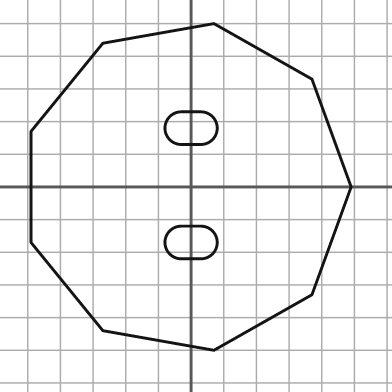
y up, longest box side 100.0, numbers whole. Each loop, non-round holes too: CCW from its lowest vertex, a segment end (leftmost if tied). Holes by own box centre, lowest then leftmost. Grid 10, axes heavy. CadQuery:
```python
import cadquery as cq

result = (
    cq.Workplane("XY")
    .moveTo(7.0, -50.0)
    .lineTo(37.0, -33.0)
    .lineTo(49.0, 0.0)
    .lineTo(37.0, 33.0)
    .lineTo(7.0, 50.0)
    .lineTo(-27.0, 44.0)
    .lineTo(-49.0, 17.0)
    .lineTo(-49.0, -17.0)
    .lineTo(-27.0, -44.0)
    .close()
    .moveTo(-3.0, -22.0)
    .lineTo(3.0, -22.0)
    .threePointArc((8.0, -17.0), (3.0, -12.0))
    .lineTo(-3.0, -12.0)
    .threePointArc((-8.0, -17.0), (-3.0, -22.0))
    .close()
    .moveTo(-3.0, 13.0)
    .lineTo(3.0, 13.0)
    .threePointArc((8.0, 18.0), (3.0, 23.0))
    .lineTo(-3.0, 23.0)
    .threePointArc((-8.0, 18.0), (-3.0, 13.0))
    .close()
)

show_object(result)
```